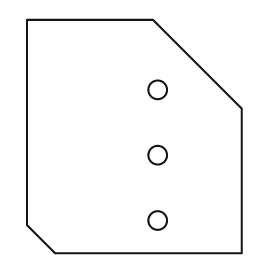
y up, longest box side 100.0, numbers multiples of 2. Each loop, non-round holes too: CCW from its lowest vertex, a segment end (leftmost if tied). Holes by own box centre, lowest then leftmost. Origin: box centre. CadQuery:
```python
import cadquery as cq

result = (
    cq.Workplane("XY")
    .moveTo(-34.0, -50.0)
    .lineTo(46.0, -50.0)
    .lineTo(46.0, 12.0)
    .lineTo(8.0, 50.0)
    .lineTo(-46.0, 50.0)
    .lineTo(-46.0, -38.0)
    .close()
    .moveTo(10.0, -36.0)
    .circle(4.0)
    .moveTo(10.0, -8.0)
    .circle(4.0)
    .moveTo(10.0, 20.0)
    .circle(4.0)
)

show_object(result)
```